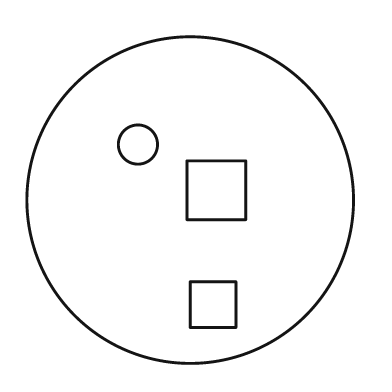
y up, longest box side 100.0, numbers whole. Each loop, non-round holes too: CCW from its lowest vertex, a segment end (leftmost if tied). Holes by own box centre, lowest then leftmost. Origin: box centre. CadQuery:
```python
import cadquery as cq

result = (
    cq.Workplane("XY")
    .moveTo(0.0, 0.0)
    .circle(50.0)
    .moveTo(0.0, -39.0)
    .lineTo(14.0, -39.0)
    .lineTo(14.0, -25.0)
    .lineTo(0.0, -25.0)
    .close()
    .moveTo(-1.0, -6.0)
    .lineTo(17.0, -6.0)
    .lineTo(17.0, 12.0)
    .lineTo(-1.0, 12.0)
    .close()
    .moveTo(-16.0, 17.0)
    .circle(6.0)
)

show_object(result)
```